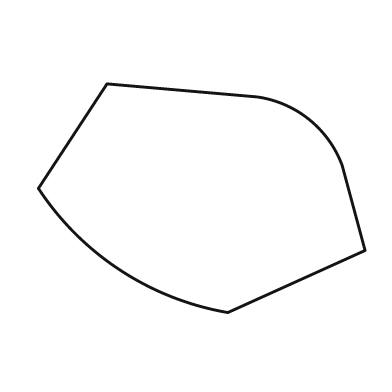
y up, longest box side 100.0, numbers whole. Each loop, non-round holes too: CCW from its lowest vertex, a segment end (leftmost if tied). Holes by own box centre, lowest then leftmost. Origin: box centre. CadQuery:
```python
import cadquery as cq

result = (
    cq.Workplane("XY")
    .moveTo(8.0, -35.0)
    .lineTo(50.0, -16.0)
    .lineTo(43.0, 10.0)
    .threePointArc((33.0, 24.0), (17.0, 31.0))
    .lineTo(-29.0, 35.0)
    .lineTo(-50.0, 3.0)
    .threePointArc((-25.0, -22.0), (8.0, -35.0))
    .close()
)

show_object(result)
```